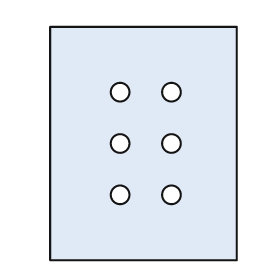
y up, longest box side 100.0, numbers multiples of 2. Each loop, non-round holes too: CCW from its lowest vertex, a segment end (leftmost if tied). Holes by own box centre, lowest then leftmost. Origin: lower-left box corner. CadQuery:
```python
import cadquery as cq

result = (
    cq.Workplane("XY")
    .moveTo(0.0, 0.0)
    .lineTo(80.0, 0.0)
    .lineTo(80.0, 100.0)
    .lineTo(0.0, 100.0)
    .close()
    .moveTo(30.0, 28.0)
    .circle(4.0)
    .moveTo(52.0, 28.0)
    .circle(4.0)
    .moveTo(30.0, 50.0)
    .circle(4.0)
    .moveTo(52.0, 50.0)
    .circle(4.0)
    .moveTo(30.0, 72.0)
    .circle(4.0)
    .moveTo(52.0, 72.0)
    .circle(4.0)
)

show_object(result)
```